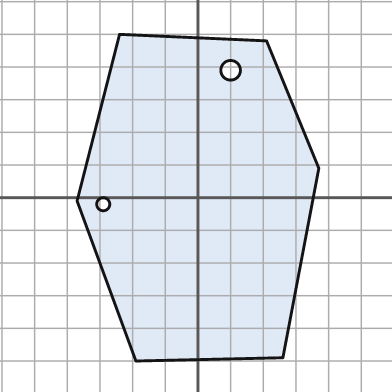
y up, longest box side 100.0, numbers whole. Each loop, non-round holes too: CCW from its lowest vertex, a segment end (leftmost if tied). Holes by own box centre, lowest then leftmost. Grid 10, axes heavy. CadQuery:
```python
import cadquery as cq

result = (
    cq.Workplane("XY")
    .moveTo(-19.0, -50.0)
    .lineTo(26.0, -49.0)
    .lineTo(37.0, 9.0)
    .lineTo(21.0, 48.0)
    .lineTo(-24.0, 50.0)
    .lineTo(-37.0, -1.0)
    .close()
    .moveTo(-29.0, -2.0)
    .circle(2.0)
    .moveTo(10.0, 39.0)
    .circle(3.0)
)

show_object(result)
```